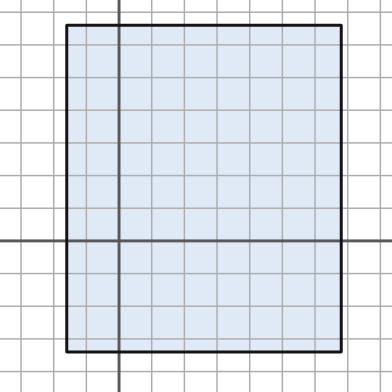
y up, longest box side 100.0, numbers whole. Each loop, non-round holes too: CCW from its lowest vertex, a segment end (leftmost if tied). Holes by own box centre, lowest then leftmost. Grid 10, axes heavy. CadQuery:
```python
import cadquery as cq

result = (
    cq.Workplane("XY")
    .moveTo(-16.0, -34.0)
    .lineTo(68.0, -34.0)
    .lineTo(68.0, 66.0)
    .lineTo(-16.0, 66.0)
    .close()
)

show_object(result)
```